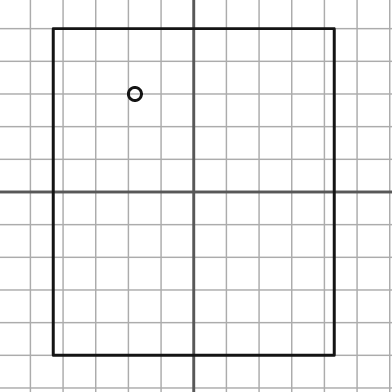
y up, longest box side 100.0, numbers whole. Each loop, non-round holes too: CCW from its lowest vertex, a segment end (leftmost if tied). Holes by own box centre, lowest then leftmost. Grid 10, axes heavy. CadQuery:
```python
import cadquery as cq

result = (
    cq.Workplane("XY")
    .moveTo(-43.0, -50.0)
    .lineTo(43.0, -50.0)
    .lineTo(43.0, 50.0)
    .lineTo(-43.0, 50.0)
    .close()
    .moveTo(-18.0, 30.0)
    .circle(2.0)
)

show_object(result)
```